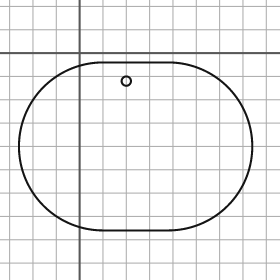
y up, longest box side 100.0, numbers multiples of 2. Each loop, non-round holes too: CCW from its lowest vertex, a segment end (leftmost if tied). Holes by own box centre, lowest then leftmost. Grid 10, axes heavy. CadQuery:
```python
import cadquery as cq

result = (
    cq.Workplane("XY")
    .moveTo(10.0, -76.0)
    .lineTo(38.0, -76.0)
    .threePointArc((74.0, -40.0), (38.0, -4.0))
    .lineTo(10.0, -4.0)
    .threePointArc((-26.0, -40.0), (10.0, -76.0))
    .close()
    .moveTo(20.0, -12.0)
    .circle(2.0)
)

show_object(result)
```